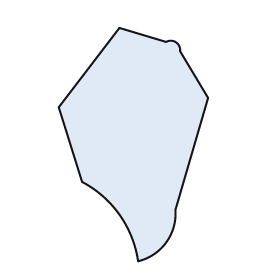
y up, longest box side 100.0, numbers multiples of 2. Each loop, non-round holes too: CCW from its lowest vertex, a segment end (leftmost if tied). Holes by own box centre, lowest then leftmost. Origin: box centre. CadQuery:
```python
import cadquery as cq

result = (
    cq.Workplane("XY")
    .moveTo(2.0, -50.0)
    .threePointArc((14.0, -42.0), (18.0, -28.0))
    .lineTo(32.0, 20.0)
    .lineTo(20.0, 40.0)
    .threePointArc((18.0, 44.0), (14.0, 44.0))
    .lineTo(-6.0, 50.0)
    .lineTo(-32.0, 16.0)
    .lineTo(-22.0, -16.0)
    .threePointArc((-6.0, -30.0), (2.0, -50.0))
    .close()
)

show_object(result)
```